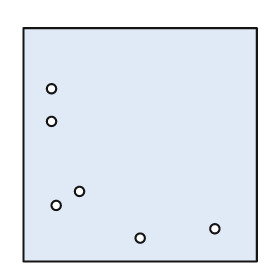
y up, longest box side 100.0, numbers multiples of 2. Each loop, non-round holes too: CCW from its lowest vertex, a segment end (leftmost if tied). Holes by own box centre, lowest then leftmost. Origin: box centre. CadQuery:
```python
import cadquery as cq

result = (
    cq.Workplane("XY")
    .moveTo(-50.0, -50.0)
    .lineTo(50.0, -50.0)
    .lineTo(50.0, 50.0)
    .lineTo(-50.0, 50.0)
    .close()
    .moveTo(0.0, -40.0)
    .circle(2.0)
    .moveTo(32.0, -36.0)
    .circle(2.0)
    .moveTo(-36.0, -26.0)
    .circle(2.0)
    .moveTo(-26.0, -20.0)
    .circle(2.0)
    .moveTo(-38.0, 10.0)
    .circle(2.0)
    .moveTo(-38.0, 24.0)
    .circle(2.0)
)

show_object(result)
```